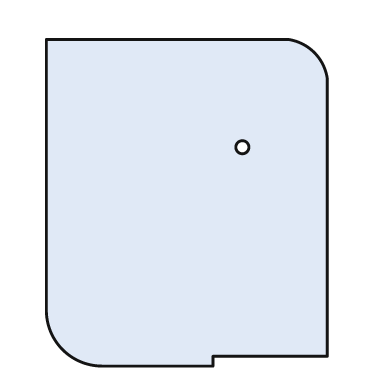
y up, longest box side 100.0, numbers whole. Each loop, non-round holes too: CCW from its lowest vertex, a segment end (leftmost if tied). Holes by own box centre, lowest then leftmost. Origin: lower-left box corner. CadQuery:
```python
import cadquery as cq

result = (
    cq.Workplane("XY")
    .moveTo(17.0, 0.0)
    .lineTo(51.0, 0.0)
    .lineTo(51.0, 3.0)
    .lineTo(86.0, 3.0)
    .lineTo(86.0, 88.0)
    .threePointArc((82.0, 96.0), (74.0, 100.0))
    .lineTo(0.0, 100.0)
    .lineTo(0.0, 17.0)
    .threePointArc((5.0, 5.0), (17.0, 0.0))
    .close()
    .moveTo(60.0, 67.0)
    .circle(2.0)
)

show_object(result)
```